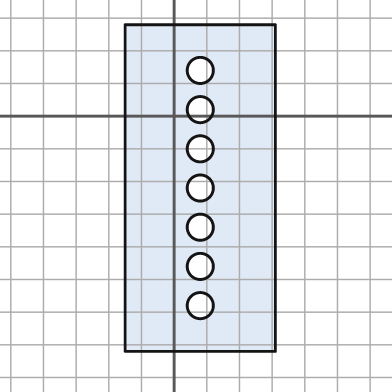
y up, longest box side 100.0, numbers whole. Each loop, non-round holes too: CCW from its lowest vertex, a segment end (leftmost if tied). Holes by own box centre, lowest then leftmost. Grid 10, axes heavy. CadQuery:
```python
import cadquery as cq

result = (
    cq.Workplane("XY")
    .moveTo(-15.0, -72.0)
    .lineTo(31.0, -72.0)
    .lineTo(31.0, 28.0)
    .lineTo(-15.0, 28.0)
    .close()
    .moveTo(8.0, -58.0)
    .circle(4.0)
    .moveTo(8.0, -46.0)
    .circle(4.0)
    .moveTo(8.0, -34.0)
    .circle(4.0)
    .moveTo(8.0, -22.0)
    .circle(4.0)
    .moveTo(8.0, -10.0)
    .circle(4.0)
    .moveTo(8.0, 2.0)
    .circle(4.0)
    .moveTo(8.0, 14.0)
    .circle(4.0)
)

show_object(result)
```